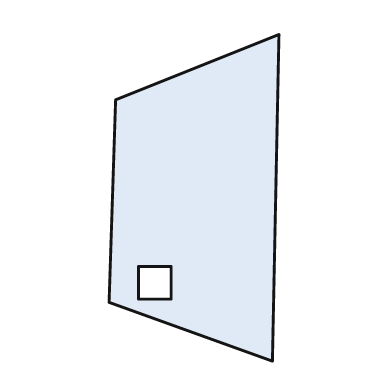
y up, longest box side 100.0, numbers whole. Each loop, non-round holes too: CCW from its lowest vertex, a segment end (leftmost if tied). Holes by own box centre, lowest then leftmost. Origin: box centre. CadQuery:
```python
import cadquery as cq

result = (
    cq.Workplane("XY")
    .moveTo(24.0, -50.0)
    .lineTo(26.0, 50.0)
    .lineTo(-24.0, 30.0)
    .lineTo(-26.0, -32.0)
    .close()
    .moveTo(-17.0, -31.0)
    .lineTo(-7.0, -31.0)
    .lineTo(-7.0, -21.0)
    .lineTo(-17.0, -21.0)
    .close()
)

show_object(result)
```